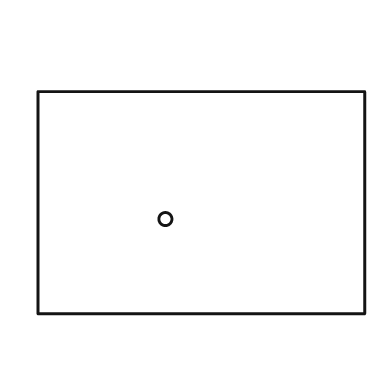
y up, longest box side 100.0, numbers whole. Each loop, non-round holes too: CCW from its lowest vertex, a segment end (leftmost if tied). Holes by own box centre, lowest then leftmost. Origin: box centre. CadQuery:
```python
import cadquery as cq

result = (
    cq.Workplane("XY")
    .moveTo(-50.0, -34.0)
    .lineTo(50.0, -34.0)
    .lineTo(50.0, 34.0)
    .lineTo(-50.0, 34.0)
    .close()
    .moveTo(-11.0, -5.0)
    .circle(2.0)
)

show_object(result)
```